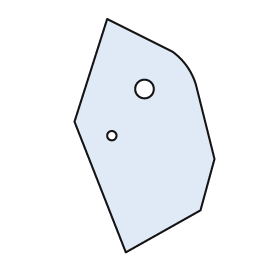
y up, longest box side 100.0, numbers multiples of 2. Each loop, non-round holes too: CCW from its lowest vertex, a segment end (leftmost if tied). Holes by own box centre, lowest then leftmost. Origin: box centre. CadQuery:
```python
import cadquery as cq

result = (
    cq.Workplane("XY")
    .moveTo(-8.0, -50.0)
    .lineTo(24.0, -32.0)
    .lineTo(30.0, -10.0)
    .lineTo(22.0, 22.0)
    .threePointArc((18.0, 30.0), (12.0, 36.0))
    .lineTo(-16.0, 50.0)
    .lineTo(-30.0, 6.0)
    .close()
    .moveTo(-14.0, 0.0)
    .circle(2.0)
    .moveTo(0.0, 20.0)
    .circle(4.0)
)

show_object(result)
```